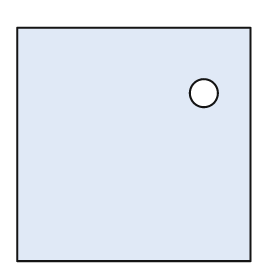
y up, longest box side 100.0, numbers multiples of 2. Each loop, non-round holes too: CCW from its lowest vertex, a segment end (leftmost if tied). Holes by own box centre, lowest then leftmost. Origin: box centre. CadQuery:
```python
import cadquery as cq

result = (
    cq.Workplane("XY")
    .moveTo(-50.0, -50.0)
    .lineTo(50.0, -50.0)
    .lineTo(50.0, 50.0)
    .lineTo(-50.0, 50.0)
    .close()
    .moveTo(30.0, 22.0)
    .circle(6.0)
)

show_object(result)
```